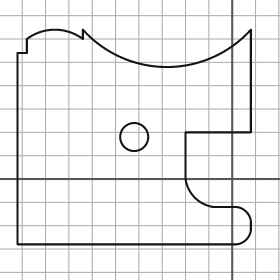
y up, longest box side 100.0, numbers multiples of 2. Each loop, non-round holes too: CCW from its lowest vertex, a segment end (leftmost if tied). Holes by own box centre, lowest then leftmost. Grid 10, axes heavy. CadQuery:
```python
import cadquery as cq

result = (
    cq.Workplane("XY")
    .moveTo(-92.0, -28.0)
    .lineTo(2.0, -28.0)
    .threePointArc((6.0, -26.0), (8.0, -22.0))
    .lineTo(8.0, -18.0)
    .threePointArc((6.0, -14.0), (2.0, -12.0))
    .lineTo(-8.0, -12.0)
    .threePointArc((-16.0, -8.0), (-20.0, 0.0))
    .lineTo(-20.0, 20.0)
    .lineTo(8.0, 20.0)
    .lineTo(8.0, 64.0)
    .threePointArc((-28.0, 48.0), (-64.0, 64.0))
    .lineTo(-64.0, 60.0)
    .threePointArc((-76.0, 64.0), (-88.0, 60.0))
    .lineTo(-88.0, 54.0)
    .lineTo(-92.0, 54.0)
    .close()
    .moveTo(-42.0, 18.0)
    .circle(6.0)
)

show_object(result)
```